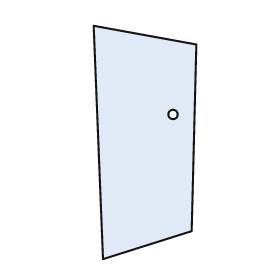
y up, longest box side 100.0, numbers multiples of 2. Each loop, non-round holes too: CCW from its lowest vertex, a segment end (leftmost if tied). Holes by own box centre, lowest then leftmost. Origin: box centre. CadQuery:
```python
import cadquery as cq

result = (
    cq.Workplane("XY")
    .moveTo(-18.0, -50.0)
    .lineTo(20.0, -38.0)
    .lineTo(22.0, 42.0)
    .lineTo(-22.0, 50.0)
    .close()
    .moveTo(12.0, 12.0)
    .circle(2.0)
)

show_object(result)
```